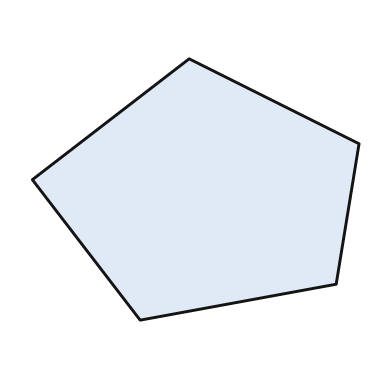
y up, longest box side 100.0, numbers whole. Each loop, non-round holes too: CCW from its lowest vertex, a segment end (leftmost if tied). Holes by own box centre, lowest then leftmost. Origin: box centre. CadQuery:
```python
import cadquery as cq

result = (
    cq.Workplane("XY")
    .moveTo(-17.0, -40.0)
    .lineTo(43.0, -29.0)
    .lineTo(50.0, 14.0)
    .lineTo(-2.0, 40.0)
    .lineTo(-50.0, 3.0)
    .close()
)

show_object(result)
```